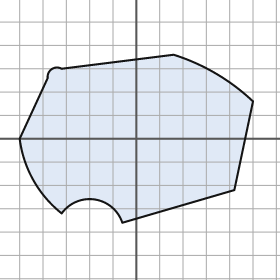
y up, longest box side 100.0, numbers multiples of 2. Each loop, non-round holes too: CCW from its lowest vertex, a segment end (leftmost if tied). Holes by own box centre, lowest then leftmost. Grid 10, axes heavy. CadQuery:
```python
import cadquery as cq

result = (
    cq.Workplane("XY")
    .moveTo(-6.0, -36.0)
    .lineTo(42.0, -22.0)
    .lineTo(50.0, 16.0)
    .threePointArc((34.0, 28.0), (16.0, 36.0))
    .lineTo(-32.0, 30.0)
    .threePointArc((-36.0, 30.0), (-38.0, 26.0))
    .lineTo(-50.0, 0.0)
    .threePointArc((-44.0, -18.0), (-32.0, -32.0))
    .threePointArc((-18.0, -26.0), (-6.0, -36.0))
    .close()
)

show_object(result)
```